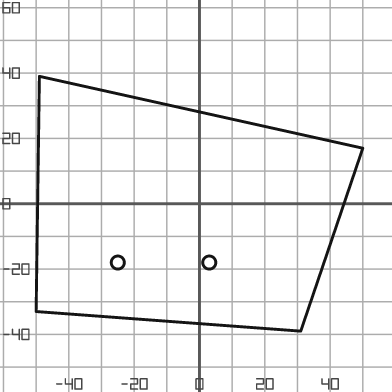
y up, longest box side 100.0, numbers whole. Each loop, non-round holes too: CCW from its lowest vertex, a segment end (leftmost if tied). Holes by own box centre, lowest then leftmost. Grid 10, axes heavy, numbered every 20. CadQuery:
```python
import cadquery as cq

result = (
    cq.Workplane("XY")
    .moveTo(31.0, -39.0)
    .lineTo(50.0, 17.0)
    .lineTo(-49.0, 39.0)
    .lineTo(-50.0, -33.0)
    .close()
    .moveTo(-25.0, -18.0)
    .circle(2.0)
    .moveTo(3.0, -18.0)
    .circle(2.0)
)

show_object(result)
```